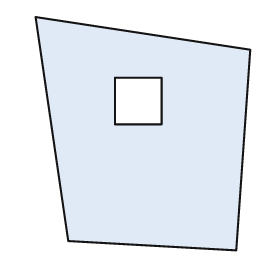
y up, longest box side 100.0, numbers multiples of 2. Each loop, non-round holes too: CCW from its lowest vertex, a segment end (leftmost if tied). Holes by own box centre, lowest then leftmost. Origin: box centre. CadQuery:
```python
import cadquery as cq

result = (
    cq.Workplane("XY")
    .moveTo(40.0, -50.0)
    .lineTo(46.0, 36.0)
    .lineTo(-46.0, 50.0)
    .lineTo(-32.0, -46.0)
    .close()
    .moveTo(-12.0, 4.0)
    .lineTo(8.0, 4.0)
    .lineTo(8.0, 24.0)
    .lineTo(-12.0, 24.0)
    .close()
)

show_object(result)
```